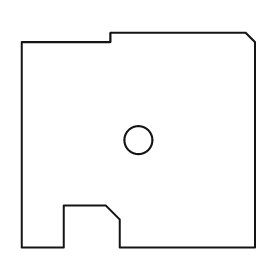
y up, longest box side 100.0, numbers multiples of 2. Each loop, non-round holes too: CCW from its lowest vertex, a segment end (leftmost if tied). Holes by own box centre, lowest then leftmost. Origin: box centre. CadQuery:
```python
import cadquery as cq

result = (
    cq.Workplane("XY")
    .moveTo(-50.0, -46.0)
    .lineTo(-32.0, -46.0)
    .lineTo(-32.0, -28.0)
    .lineTo(-14.0, -28.0)
    .lineTo(-8.0, -34.0)
    .lineTo(-8.0, -46.0)
    .lineTo(50.0, -46.0)
    .lineTo(50.0, 42.0)
    .lineTo(46.0, 46.0)
    .lineTo(-12.0, 46.0)
    .lineTo(-12.0, 42.0)
    .lineTo(-50.0, 42.0)
    .close()
    .moveTo(0.0, 0.0)
    .circle(6.0)
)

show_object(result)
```